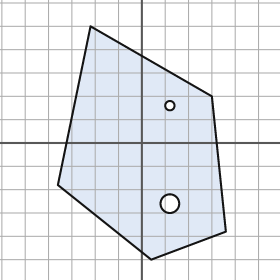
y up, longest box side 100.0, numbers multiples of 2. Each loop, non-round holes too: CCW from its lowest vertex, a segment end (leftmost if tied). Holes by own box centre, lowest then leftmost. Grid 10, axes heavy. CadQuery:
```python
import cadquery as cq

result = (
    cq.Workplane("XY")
    .moveTo(4.0, -50.0)
    .lineTo(36.0, -38.0)
    .lineTo(30.0, 20.0)
    .lineTo(-22.0, 50.0)
    .lineTo(-36.0, -18.0)
    .close()
    .moveTo(12.0, -26.0)
    .circle(4.0)
    .moveTo(12.0, 16.0)
    .circle(2.0)
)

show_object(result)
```